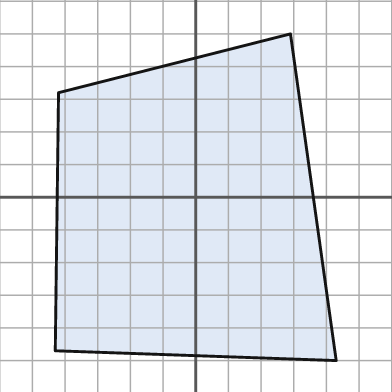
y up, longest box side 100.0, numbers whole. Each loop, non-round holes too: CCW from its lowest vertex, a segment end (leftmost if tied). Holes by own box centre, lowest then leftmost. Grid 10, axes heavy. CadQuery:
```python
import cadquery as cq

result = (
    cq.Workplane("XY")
    .moveTo(43.0, -50.0)
    .lineTo(29.0, 50.0)
    .lineTo(-42.0, 32.0)
    .lineTo(-43.0, -47.0)
    .close()
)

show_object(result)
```